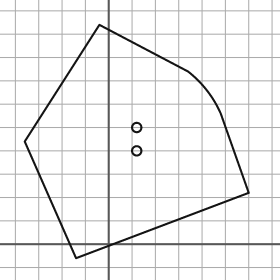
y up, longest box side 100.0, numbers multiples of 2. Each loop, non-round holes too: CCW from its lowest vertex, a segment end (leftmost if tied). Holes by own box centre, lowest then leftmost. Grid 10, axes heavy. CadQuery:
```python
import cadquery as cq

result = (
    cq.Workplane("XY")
    .moveTo(-14.0, -6.0)
    .lineTo(60.0, 22.0)
    .lineTo(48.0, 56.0)
    .threePointArc((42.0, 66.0), (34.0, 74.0))
    .lineTo(-4.0, 94.0)
    .lineTo(-36.0, 44.0)
    .close()
    .moveTo(12.0, 40.0)
    .circle(2.0)
    .moveTo(12.0, 50.0)
    .circle(2.0)
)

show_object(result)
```